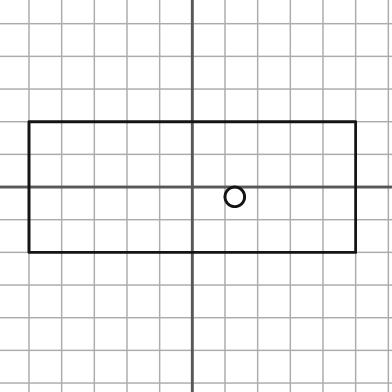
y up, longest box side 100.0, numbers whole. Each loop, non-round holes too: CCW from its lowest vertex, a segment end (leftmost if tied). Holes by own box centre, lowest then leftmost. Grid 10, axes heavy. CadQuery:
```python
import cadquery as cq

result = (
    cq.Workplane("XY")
    .moveTo(-50.0, -20.0)
    .lineTo(50.0, -20.0)
    .lineTo(50.0, 20.0)
    .lineTo(-50.0, 20.0)
    .close()
    .moveTo(13.0, -3.0)
    .circle(3.0)
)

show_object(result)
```